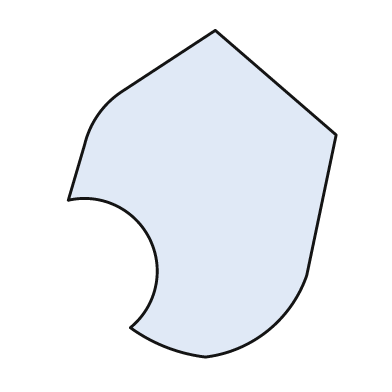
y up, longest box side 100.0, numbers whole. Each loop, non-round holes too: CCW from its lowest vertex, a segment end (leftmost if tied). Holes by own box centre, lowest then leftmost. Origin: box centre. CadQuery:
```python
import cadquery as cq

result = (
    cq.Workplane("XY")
    .moveTo(1.0, -50.0)
    .threePointArc((20.0, -42.0), (32.0, -25.0))
    .lineTo(41.0, 18.0)
    .lineTo(4.0, 50.0)
    .lineTo(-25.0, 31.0)
    .threePointArc((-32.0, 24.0), (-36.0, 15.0))
    .lineTo(-41.0, -2.0)
    .threePointArc((-16.0, -14.0), (-22.0, -41.0))
    .threePointArc((-11.0, -47.0), (1.0, -50.0))
    .close()
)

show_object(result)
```